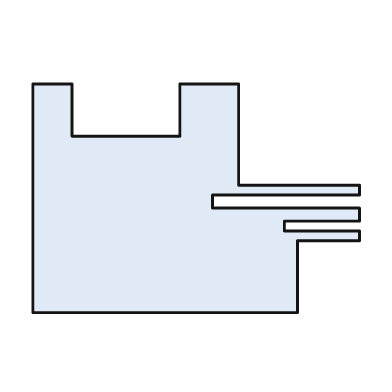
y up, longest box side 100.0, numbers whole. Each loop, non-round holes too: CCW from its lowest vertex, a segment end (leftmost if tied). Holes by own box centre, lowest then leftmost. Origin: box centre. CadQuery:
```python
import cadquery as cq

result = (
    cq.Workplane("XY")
    .moveTo(-50.0, -35.0)
    .lineTo(31.0, -35.0)
    .lineTo(31.0, -13.0)
    .lineTo(50.0, -13.0)
    .lineTo(50.0, -10.0)
    .lineTo(27.0, -10.0)
    .lineTo(27.0, -7.0)
    .lineTo(50.0, -7.0)
    .lineTo(50.0, -3.0)
    .lineTo(5.0, -3.0)
    .lineTo(5.0, 1.0)
    .lineTo(50.0, 1.0)
    .lineTo(50.0, 4.0)
    .lineTo(13.0, 4.0)
    .lineTo(13.0, 35.0)
    .lineTo(-5.0, 35.0)
    .lineTo(-5.0, 19.0)
    .lineTo(-38.0, 19.0)
    .lineTo(-38.0, 35.0)
    .lineTo(-50.0, 35.0)
    .close()
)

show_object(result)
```